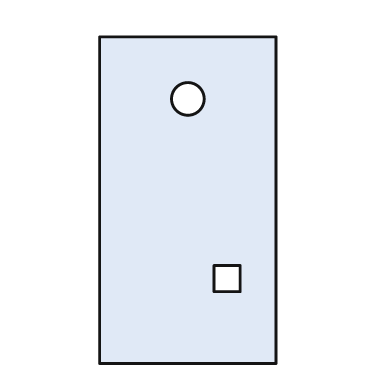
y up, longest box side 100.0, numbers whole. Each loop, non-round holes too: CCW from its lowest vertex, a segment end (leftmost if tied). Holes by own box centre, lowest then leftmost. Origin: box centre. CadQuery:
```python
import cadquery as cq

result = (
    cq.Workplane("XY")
    .moveTo(-27.0, -50.0)
    .lineTo(27.0, -50.0)
    .lineTo(27.0, 50.0)
    .lineTo(-27.0, 50.0)
    .close()
    .moveTo(8.0, -28.0)
    .lineTo(16.0, -28.0)
    .lineTo(16.0, -20.0)
    .lineTo(8.0, -20.0)
    .close()
    .moveTo(0.0, 31.0)
    .circle(5.0)
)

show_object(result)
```